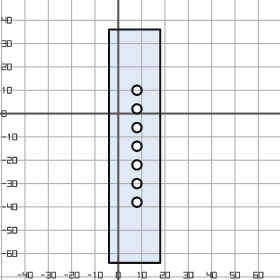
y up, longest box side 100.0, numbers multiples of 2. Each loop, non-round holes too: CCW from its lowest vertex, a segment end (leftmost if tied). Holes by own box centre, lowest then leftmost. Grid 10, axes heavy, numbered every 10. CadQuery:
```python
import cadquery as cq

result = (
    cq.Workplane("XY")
    .moveTo(-4.0, -64.0)
    .lineTo(18.0, -64.0)
    .lineTo(18.0, 36.0)
    .lineTo(-4.0, 36.0)
    .close()
    .moveTo(8.0, -38.0)
    .circle(2.0)
    .moveTo(8.0, -30.0)
    .circle(2.0)
    .moveTo(8.0, -22.0)
    .circle(2.0)
    .moveTo(8.0, -14.0)
    .circle(2.0)
    .moveTo(8.0, -6.0)
    .circle(2.0)
    .moveTo(8.0, 2.0)
    .circle(2.0)
    .moveTo(8.0, 10.0)
    .circle(2.0)
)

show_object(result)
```